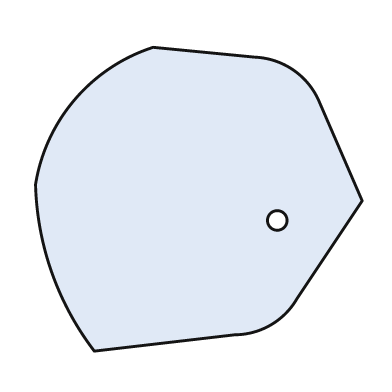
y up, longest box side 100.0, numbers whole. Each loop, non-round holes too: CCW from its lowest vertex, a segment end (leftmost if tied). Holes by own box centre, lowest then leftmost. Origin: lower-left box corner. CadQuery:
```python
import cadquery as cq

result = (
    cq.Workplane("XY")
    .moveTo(18.0, 0.0)
    .lineTo(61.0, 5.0)
    .threePointArc((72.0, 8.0), (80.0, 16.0))
    .lineTo(100.0, 46.0)
    .lineTo(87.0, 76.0)
    .threePointArc((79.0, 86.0), (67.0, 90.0))
    .lineTo(36.0, 93.0)
    .threePointArc((12.0, 77.0), (0.0, 51.0))
    .threePointArc((5.0, 24.0), (18.0, 0.0))
    .close()
    .moveTo(74.0, 40.0)
    .circle(3.0)
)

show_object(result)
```